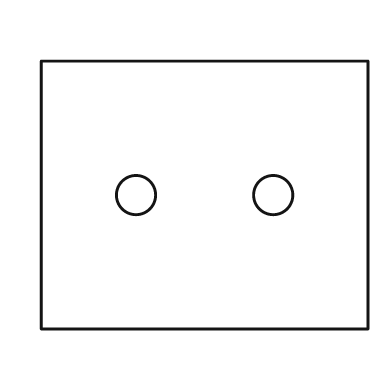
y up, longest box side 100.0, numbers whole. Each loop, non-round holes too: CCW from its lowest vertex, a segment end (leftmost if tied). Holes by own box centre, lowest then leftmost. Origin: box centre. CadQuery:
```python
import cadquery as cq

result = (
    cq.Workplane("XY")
    .moveTo(-50.0, -41.0)
    .lineTo(50.0, -41.0)
    .lineTo(50.0, 41.0)
    .lineTo(-50.0, 41.0)
    .close()
    .moveTo(-21.0, 0.0)
    .circle(6.0)
    .moveTo(21.0, 0.0)
    .circle(6.0)
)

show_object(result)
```